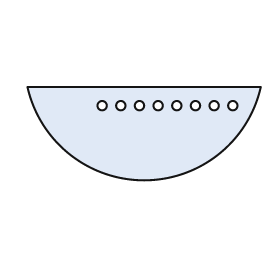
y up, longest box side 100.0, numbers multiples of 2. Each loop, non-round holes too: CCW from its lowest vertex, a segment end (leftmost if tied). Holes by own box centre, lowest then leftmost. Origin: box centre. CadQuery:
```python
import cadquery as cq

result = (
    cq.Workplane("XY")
    .moveTo(-50.0, 20.0)
    .threePointArc((0.0, -20.0), (50.0, 20.0))
    .close()
    .moveTo(-18.0, 12.0)
    .circle(2.0)
    .moveTo(-10.0, 12.0)
    .circle(2.0)
    .moveTo(-2.0, 12.0)
    .circle(2.0)
    .moveTo(6.0, 12.0)
    .circle(2.0)
    .moveTo(14.0, 12.0)
    .circle(2.0)
    .moveTo(22.0, 12.0)
    .circle(2.0)
    .moveTo(30.0, 12.0)
    .circle(2.0)
    .moveTo(38.0, 12.0)
    .circle(2.0)
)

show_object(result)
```